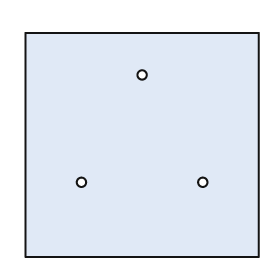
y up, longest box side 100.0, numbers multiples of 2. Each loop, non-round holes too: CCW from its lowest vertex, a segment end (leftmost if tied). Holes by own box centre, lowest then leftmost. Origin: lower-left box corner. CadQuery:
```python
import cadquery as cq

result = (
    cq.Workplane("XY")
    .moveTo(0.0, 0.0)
    .lineTo(100.0, 0.0)
    .lineTo(100.0, 96.0)
    .lineTo(0.0, 96.0)
    .close()
    .moveTo(24.0, 32.0)
    .circle(2.0)
    .moveTo(76.0, 32.0)
    .circle(2.0)
    .moveTo(50.0, 78.0)
    .circle(2.0)
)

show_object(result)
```